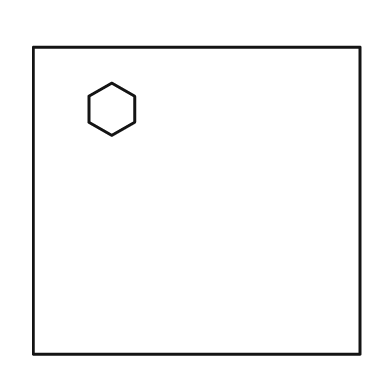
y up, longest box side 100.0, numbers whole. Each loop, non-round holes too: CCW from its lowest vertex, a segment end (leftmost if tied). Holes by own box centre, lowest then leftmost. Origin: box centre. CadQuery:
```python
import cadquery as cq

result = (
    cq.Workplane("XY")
    .moveTo(-50.0, -47.0)
    .lineTo(50.0, -47.0)
    .lineTo(50.0, 47.0)
    .lineTo(-50.0, 47.0)
    .close()
    .moveTo(-26.0, 20.0)
    .lineTo(-19.0, 24.0)
    .lineTo(-19.0, 32.0)
    .lineTo(-26.0, 36.0)
    .lineTo(-33.0, 32.0)
    .lineTo(-33.0, 24.0)
    .close()
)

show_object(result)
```